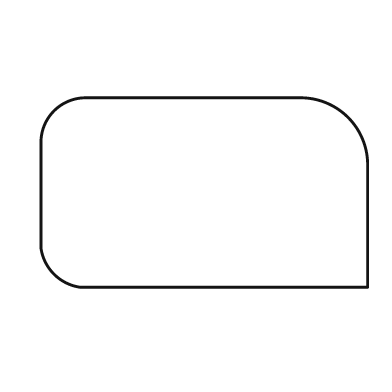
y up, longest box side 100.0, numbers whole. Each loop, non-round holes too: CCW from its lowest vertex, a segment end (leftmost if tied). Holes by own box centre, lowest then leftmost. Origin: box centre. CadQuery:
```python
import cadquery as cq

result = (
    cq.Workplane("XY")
    .moveTo(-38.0, -29.0)
    .lineTo(50.0, -29.0)
    .lineTo(50.0, 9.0)
    .threePointArc((44.0, 23.0), (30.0, 29.0))
    .lineTo(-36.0, 29.0)
    .threePointArc((-46.0, 25.0), (-50.0, 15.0))
    .lineTo(-50.0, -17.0)
    .threePointArc((-46.0, -25.0), (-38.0, -29.0))
    .close()
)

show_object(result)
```